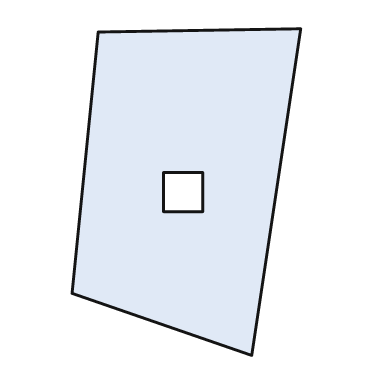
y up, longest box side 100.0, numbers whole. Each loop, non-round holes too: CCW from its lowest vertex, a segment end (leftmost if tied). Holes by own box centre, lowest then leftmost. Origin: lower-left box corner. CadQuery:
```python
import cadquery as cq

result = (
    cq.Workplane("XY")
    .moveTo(55.0, 0.0)
    .lineTo(70.0, 100.0)
    .lineTo(8.0, 99.0)
    .lineTo(0.0, 19.0)
    .close()
    .moveTo(28.0, 44.0)
    .lineTo(40.0, 44.0)
    .lineTo(40.0, 56.0)
    .lineTo(28.0, 56.0)
    .close()
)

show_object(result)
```